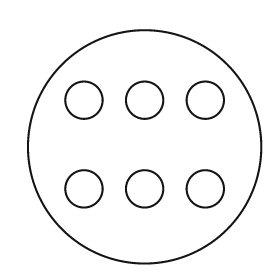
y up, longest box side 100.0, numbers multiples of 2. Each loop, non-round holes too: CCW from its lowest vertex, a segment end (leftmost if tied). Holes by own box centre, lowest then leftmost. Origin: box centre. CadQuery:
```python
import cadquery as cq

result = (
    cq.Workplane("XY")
    .moveTo(0.0, 0.0)
    .circle(50.0)
    .moveTo(-26.0, -18.0)
    .circle(8.0)
    .moveTo(0.0, -18.0)
    .circle(8.0)
    .moveTo(26.0, -18.0)
    .circle(8.0)
    .moveTo(-26.0, 20.0)
    .circle(8.0)
    .moveTo(0.0, 20.0)
    .circle(8.0)
    .moveTo(26.0, 20.0)
    .circle(8.0)
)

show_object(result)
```